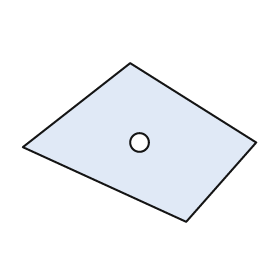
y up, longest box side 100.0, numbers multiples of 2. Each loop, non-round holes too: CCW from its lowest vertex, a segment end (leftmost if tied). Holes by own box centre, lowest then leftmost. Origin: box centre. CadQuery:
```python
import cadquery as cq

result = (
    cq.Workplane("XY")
    .moveTo(20.0, -34.0)
    .lineTo(50.0, 0.0)
    .lineTo(-4.0, 34.0)
    .lineTo(-50.0, -2.0)
    .close()
    .moveTo(0.0, 0.0)
    .circle(4.0)
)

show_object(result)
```